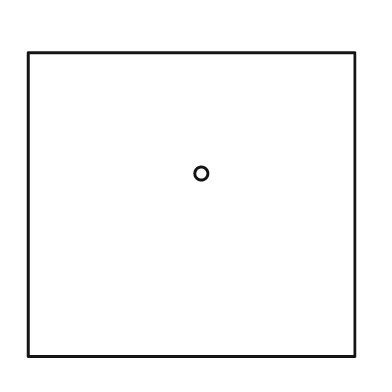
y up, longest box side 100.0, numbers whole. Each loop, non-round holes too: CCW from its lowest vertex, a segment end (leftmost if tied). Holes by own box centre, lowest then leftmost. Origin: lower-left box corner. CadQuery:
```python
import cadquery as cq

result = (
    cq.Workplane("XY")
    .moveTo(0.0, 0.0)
    .lineTo(100.0, 0.0)
    .lineTo(100.0, 93.0)
    .lineTo(0.0, 93.0)
    .close()
    .moveTo(53.0, 56.0)
    .circle(2.0)
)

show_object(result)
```